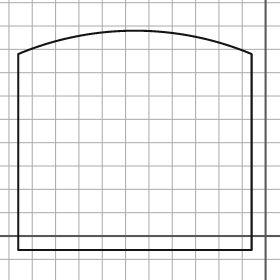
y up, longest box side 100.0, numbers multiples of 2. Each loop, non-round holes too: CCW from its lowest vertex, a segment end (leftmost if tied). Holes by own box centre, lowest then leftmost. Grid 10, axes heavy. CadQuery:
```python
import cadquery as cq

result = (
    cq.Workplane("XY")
    .moveTo(-106.0, -6.0)
    .lineTo(-6.0, -6.0)
    .lineTo(-6.0, 78.0)
    .threePointArc((-56.0, 88.0), (-106.0, 78.0))
    .close()
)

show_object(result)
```